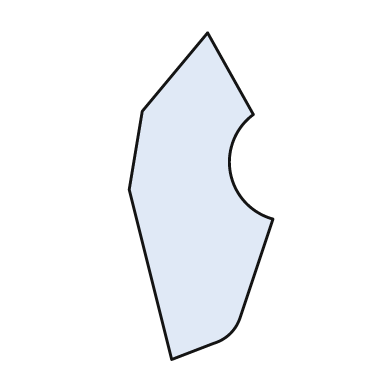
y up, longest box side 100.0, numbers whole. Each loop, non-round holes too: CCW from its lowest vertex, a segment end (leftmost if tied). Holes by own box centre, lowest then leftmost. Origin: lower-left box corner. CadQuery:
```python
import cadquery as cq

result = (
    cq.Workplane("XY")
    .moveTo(13.0, 0.0)
    .lineTo(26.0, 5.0)
    .threePointArc((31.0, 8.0), (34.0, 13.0))
    .lineTo(44.0, 43.0)
    .threePointArc((31.0, 57.0), (38.0, 75.0))
    .lineTo(24.0, 100.0)
    .lineTo(4.0, 76.0)
    .lineTo(0.0, 52.0)
    .close()
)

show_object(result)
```